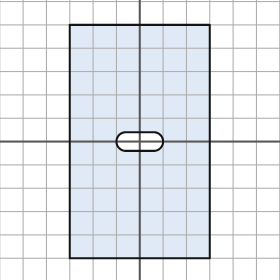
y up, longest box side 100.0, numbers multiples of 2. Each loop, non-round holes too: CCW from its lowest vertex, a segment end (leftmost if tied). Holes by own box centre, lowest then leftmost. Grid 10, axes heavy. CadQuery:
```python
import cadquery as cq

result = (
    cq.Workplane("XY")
    .moveTo(-30.0, -50.0)
    .lineTo(30.0, -50.0)
    .lineTo(30.0, 50.0)
    .lineTo(-30.0, 50.0)
    .close()
    .moveTo(-6.0, -4.0)
    .lineTo(6.0, -4.0)
    .threePointArc((10.0, 0.0), (6.0, 4.0))
    .lineTo(-6.0, 4.0)
    .threePointArc((-10.0, 0.0), (-6.0, -4.0))
    .close()
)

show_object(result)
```